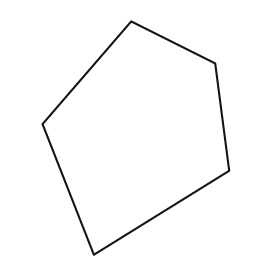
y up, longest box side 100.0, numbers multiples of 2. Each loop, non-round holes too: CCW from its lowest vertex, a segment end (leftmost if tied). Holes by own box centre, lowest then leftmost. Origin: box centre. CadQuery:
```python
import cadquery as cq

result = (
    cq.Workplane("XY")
    .moveTo(-18.0, -50.0)
    .lineTo(40.0, -14.0)
    .lineTo(34.0, 32.0)
    .lineTo(-2.0, 50.0)
    .lineTo(-40.0, 6.0)
    .close()
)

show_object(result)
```